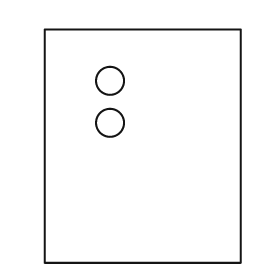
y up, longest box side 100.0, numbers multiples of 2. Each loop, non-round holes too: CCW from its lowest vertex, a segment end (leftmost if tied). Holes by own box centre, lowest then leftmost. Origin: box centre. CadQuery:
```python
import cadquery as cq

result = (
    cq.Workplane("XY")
    .moveTo(-42.0, -50.0)
    .lineTo(42.0, -50.0)
    .lineTo(42.0, 50.0)
    .lineTo(-42.0, 50.0)
    .close()
    .moveTo(-14.0, 10.0)
    .circle(6.0)
    .moveTo(-14.0, 28.0)
    .circle(6.0)
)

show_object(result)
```